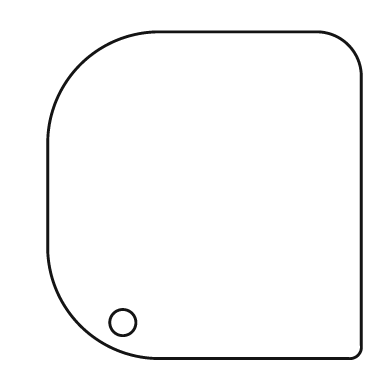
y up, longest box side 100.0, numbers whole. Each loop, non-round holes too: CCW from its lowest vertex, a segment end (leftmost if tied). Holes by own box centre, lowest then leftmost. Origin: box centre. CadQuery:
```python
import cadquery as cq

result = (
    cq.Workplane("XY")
    .moveTo(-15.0, -50.0)
    .lineTo(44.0, -50.0)
    .threePointArc((47.0, -49.0), (48.0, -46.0))
    .lineTo(48.0, 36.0)
    .threePointArc((44.0, 46.0), (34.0, 50.0))
    .lineTo(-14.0, 50.0)
    .threePointArc((-38.0, 40.0), (-48.0, 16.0))
    .lineTo(-48.0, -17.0)
    .threePointArc((-38.0, -40.0), (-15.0, -50.0))
    .close()
    .moveTo(-25.0, -39.0)
    .circle(4.0)
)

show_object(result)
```